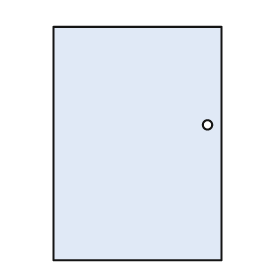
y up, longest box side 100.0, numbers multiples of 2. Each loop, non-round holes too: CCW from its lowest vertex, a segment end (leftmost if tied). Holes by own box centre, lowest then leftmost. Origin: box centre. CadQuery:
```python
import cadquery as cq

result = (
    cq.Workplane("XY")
    .moveTo(-36.0, -50.0)
    .lineTo(36.0, -50.0)
    .lineTo(36.0, 50.0)
    .lineTo(-36.0, 50.0)
    .close()
    .moveTo(30.0, 8.0)
    .circle(2.0)
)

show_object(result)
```